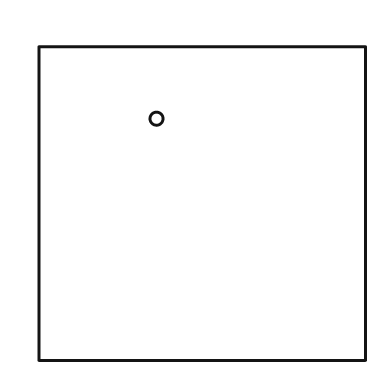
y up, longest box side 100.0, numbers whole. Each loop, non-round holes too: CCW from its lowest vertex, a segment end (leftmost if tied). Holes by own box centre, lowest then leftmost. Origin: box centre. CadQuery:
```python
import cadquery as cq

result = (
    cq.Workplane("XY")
    .moveTo(-50.0, -48.0)
    .lineTo(50.0, -48.0)
    .lineTo(50.0, 48.0)
    .lineTo(-50.0, 48.0)
    .close()
    .moveTo(-14.0, 26.0)
    .circle(2.0)
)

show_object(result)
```